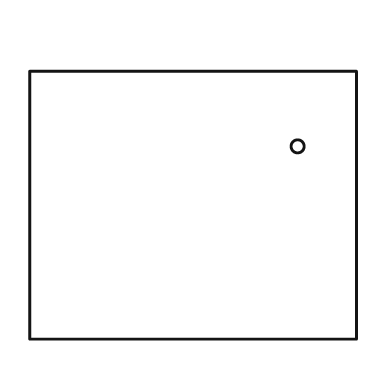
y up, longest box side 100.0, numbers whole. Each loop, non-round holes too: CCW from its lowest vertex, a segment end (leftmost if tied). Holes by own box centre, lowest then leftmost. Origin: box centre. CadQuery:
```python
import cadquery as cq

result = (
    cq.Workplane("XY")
    .moveTo(-50.0, -41.0)
    .lineTo(50.0, -41.0)
    .lineTo(50.0, 41.0)
    .lineTo(-50.0, 41.0)
    .close()
    .moveTo(32.0, 18.0)
    .circle(2.0)
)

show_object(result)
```